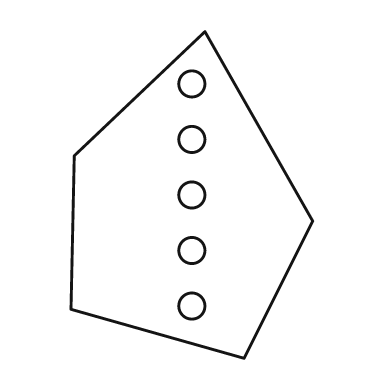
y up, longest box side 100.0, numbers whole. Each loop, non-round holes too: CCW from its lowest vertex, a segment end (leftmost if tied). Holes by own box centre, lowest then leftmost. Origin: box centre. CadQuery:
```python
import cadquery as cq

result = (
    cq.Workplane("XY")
    .moveTo(16.0, -50.0)
    .lineTo(37.0, -8.0)
    .lineTo(4.0, 50.0)
    .lineTo(-36.0, 12.0)
    .lineTo(-37.0, -35.0)
    .close()
    .moveTo(0.0, -34.0)
    .circle(4.0)
    .moveTo(0.0, -17.0)
    .circle(4.0)
    .moveTo(0.0, 0.0)
    .circle(4.0)
    .moveTo(0.0, 17.0)
    .circle(4.0)
    .moveTo(0.0, 34.0)
    .circle(4.0)
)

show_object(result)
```